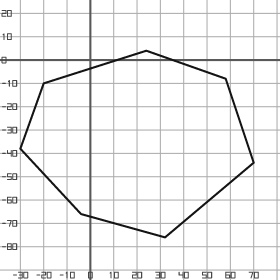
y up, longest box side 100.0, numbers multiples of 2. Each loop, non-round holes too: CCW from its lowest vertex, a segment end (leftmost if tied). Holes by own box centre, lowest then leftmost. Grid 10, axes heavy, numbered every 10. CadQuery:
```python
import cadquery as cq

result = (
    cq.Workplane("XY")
    .moveTo(32.0, -76.0)
    .lineTo(70.0, -44.0)
    .lineTo(58.0, -8.0)
    .lineTo(24.0, 4.0)
    .lineTo(-20.0, -10.0)
    .lineTo(-30.0, -38.0)
    .lineTo(-4.0, -66.0)
    .close()
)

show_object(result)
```